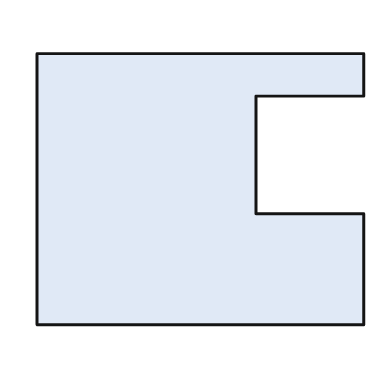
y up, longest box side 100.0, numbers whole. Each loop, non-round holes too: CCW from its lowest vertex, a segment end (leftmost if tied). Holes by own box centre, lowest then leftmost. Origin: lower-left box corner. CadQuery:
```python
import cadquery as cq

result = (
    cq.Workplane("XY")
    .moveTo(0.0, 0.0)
    .lineTo(100.0, 0.0)
    .lineTo(100.0, 34.0)
    .lineTo(67.0, 34.0)
    .lineTo(67.0, 70.0)
    .lineTo(100.0, 70.0)
    .lineTo(100.0, 83.0)
    .lineTo(0.0, 83.0)
    .close()
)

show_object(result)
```